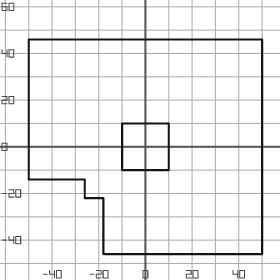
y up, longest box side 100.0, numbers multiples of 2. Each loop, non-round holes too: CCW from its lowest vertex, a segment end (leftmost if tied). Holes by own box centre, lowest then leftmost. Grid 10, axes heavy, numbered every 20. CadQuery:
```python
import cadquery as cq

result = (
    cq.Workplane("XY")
    .moveTo(-18.0, -46.0)
    .lineTo(50.0, -46.0)
    .lineTo(50.0, 46.0)
    .lineTo(-50.0, 46.0)
    .lineTo(-50.0, -14.0)
    .lineTo(-26.0, -14.0)
    .lineTo(-26.0, -22.0)
    .lineTo(-18.0, -22.0)
    .close()
    .moveTo(-10.0, -10.0)
    .lineTo(10.0, -10.0)
    .lineTo(10.0, 10.0)
    .lineTo(-10.0, 10.0)
    .close()
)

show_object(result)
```